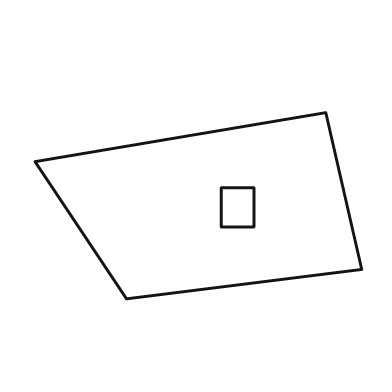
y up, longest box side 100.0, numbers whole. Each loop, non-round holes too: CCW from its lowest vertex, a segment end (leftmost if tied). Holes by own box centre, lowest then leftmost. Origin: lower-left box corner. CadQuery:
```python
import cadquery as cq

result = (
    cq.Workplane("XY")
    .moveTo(28.0, 0.0)
    .lineTo(100.0, 9.0)
    .lineTo(89.0, 57.0)
    .lineTo(0.0, 42.0)
    .close()
    .moveTo(57.0, 22.0)
    .lineTo(67.0, 22.0)
    .lineTo(67.0, 34.0)
    .lineTo(57.0, 34.0)
    .close()
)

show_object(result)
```